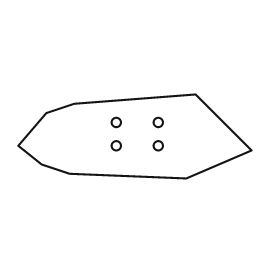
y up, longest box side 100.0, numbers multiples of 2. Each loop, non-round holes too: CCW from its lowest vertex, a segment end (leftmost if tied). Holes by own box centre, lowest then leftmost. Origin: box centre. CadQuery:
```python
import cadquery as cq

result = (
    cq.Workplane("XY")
    .moveTo(22.0, -18.0)
    .lineTo(50.0, -6.0)
    .lineTo(26.0, 18.0)
    .lineTo(-26.0, 14.0)
    .lineTo(-38.0, 10.0)
    .lineTo(-50.0, -4.0)
    .lineTo(-40.0, -12.0)
    .lineTo(-28.0, -16.0)
    .close()
    .moveTo(-8.0, -4.0)
    .circle(2.0)
    .moveTo(10.0, -4.0)
    .circle(2.0)
    .moveTo(-8.0, 6.0)
    .circle(2.0)
    .moveTo(10.0, 6.0)
    .circle(2.0)
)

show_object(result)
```